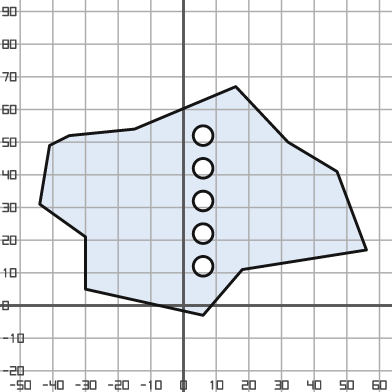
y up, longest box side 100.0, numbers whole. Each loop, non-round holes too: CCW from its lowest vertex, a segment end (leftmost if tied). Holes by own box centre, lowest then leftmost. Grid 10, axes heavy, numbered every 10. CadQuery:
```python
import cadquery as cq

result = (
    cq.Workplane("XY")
    .moveTo(6.0, -3.0)
    .lineTo(18.0, 11.0)
    .lineTo(56.0, 17.0)
    .lineTo(47.0, 41.0)
    .lineTo(32.0, 50.0)
    .lineTo(16.0, 67.0)
    .lineTo(-15.0, 54.0)
    .lineTo(-35.0, 52.0)
    .lineTo(-41.0, 49.0)
    .lineTo(-44.0, 31.0)
    .lineTo(-30.0, 21.0)
    .lineTo(-30.0, 5.0)
    .close()
    .moveTo(6.0, 12.0)
    .circle(3.0)
    .moveTo(6.0, 22.0)
    .circle(3.0)
    .moveTo(6.0, 32.0)
    .circle(3.0)
    .moveTo(6.0, 42.0)
    .circle(3.0)
    .moveTo(6.0, 52.0)
    .circle(3.0)
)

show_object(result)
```